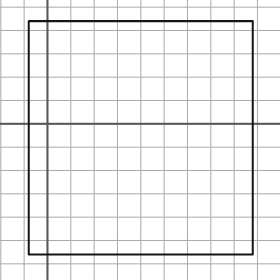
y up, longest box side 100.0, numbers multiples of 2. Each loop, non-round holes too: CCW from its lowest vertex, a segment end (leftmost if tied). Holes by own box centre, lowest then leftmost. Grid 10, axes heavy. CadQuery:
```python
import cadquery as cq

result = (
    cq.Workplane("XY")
    .moveTo(-8.0, -56.0)
    .lineTo(88.0, -56.0)
    .lineTo(88.0, 44.0)
    .lineTo(-8.0, 44.0)
    .close()
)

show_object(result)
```